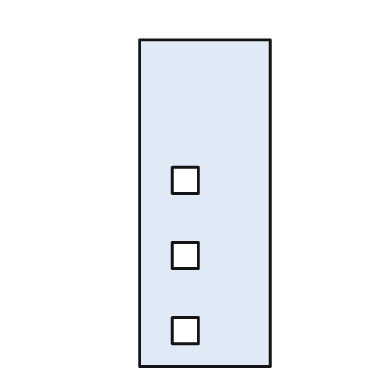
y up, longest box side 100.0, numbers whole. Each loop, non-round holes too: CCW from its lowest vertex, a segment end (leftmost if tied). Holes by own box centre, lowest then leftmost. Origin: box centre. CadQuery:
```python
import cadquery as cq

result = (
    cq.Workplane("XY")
    .moveTo(-20.0, -50.0)
    .lineTo(20.0, -50.0)
    .lineTo(20.0, 50.0)
    .lineTo(-20.0, 50.0)
    .close()
    .moveTo(-10.0, -43.0)
    .lineTo(-2.0, -43.0)
    .lineTo(-2.0, -35.0)
    .lineTo(-10.0, -35.0)
    .close()
    .moveTo(-10.0, -20.0)
    .lineTo(-2.0, -20.0)
    .lineTo(-2.0, -12.0)
    .lineTo(-10.0, -12.0)
    .close()
    .moveTo(-10.0, 3.0)
    .lineTo(-2.0, 3.0)
    .lineTo(-2.0, 11.0)
    .lineTo(-10.0, 11.0)
    .close()
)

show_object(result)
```